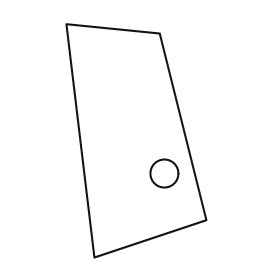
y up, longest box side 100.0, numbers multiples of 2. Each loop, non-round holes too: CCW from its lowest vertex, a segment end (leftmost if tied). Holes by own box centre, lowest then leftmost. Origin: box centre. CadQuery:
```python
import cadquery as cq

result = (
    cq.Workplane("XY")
    .moveTo(-18.0, -50.0)
    .lineTo(30.0, -34.0)
    .lineTo(10.0, 46.0)
    .lineTo(-30.0, 50.0)
    .close()
    .moveTo(12.0, -14.0)
    .circle(6.0)
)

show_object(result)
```